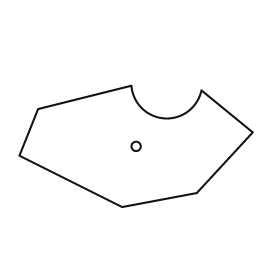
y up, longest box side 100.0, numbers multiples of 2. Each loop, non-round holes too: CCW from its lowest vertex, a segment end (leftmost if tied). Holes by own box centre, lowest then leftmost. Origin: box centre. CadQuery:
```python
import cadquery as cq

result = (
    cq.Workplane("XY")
    .moveTo(-6.0, -26.0)
    .lineTo(26.0, -20.0)
    .lineTo(50.0, 6.0)
    .lineTo(28.0, 24.0)
    .threePointArc((12.0, 12.0), (-2.0, 26.0))
    .lineTo(-42.0, 16.0)
    .lineTo(-50.0, -4.0)
    .close()
    .moveTo(0.0, 0.0)
    .circle(2.0)
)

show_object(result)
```